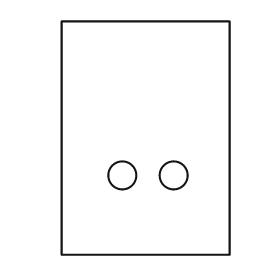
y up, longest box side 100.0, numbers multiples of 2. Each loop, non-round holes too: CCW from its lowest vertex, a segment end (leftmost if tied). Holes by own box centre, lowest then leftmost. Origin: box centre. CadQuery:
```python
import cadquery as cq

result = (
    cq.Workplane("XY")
    .moveTo(-36.0, -50.0)
    .lineTo(36.0, -50.0)
    .lineTo(36.0, 50.0)
    .lineTo(-36.0, 50.0)
    .close()
    .moveTo(-10.0, -16.0)
    .circle(6.0)
    .moveTo(12.0, -16.0)
    .circle(6.0)
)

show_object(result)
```